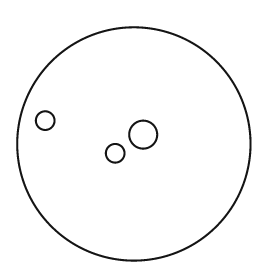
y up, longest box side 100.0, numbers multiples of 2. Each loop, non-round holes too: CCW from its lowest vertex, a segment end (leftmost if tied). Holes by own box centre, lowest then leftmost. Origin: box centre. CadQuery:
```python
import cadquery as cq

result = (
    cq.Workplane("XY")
    .moveTo(0.0, 0.0)
    .circle(50.0)
    .moveTo(-8.0, -4.0)
    .circle(4.0)
    .moveTo(4.0, 4.0)
    .circle(6.0)
    .moveTo(-38.0, 10.0)
    .circle(4.0)
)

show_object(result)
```